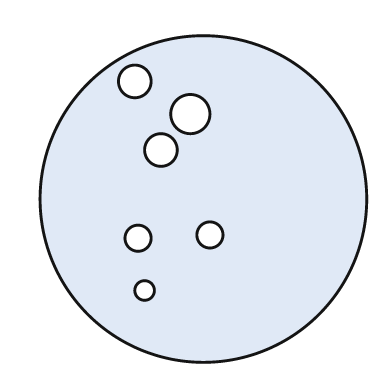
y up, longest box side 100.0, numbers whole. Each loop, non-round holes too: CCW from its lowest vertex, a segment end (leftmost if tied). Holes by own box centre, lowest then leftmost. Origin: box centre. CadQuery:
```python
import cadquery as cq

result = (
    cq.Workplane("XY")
    .moveTo(0.0, 0.0)
    .circle(50.0)
    .moveTo(-18.0, -28.0)
    .circle(3.0)
    .moveTo(-20.0, -12.0)
    .circle(4.0)
    .moveTo(2.0, -11.0)
    .circle(4.0)
    .moveTo(-13.0, 15.0)
    .circle(5.0)
    .moveTo(-4.0, 26.0)
    .circle(6.0)
    .moveTo(-21.0, 36.0)
    .circle(5.0)
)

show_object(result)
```